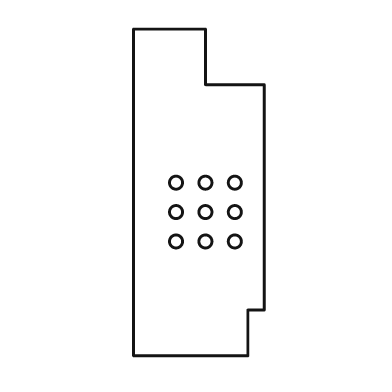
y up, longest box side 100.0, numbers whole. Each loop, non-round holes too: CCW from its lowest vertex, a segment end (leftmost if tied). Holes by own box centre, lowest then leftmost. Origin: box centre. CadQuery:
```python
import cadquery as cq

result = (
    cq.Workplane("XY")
    .moveTo(-20.0, -50.0)
    .lineTo(15.0, -50.0)
    .lineTo(15.0, -36.0)
    .lineTo(20.0, -36.0)
    .lineTo(20.0, 33.0)
    .lineTo(2.0, 33.0)
    .lineTo(2.0, 50.0)
    .lineTo(-20.0, 50.0)
    .close()
    .moveTo(-7.0, -15.0)
    .circle(2.0)
    .moveTo(2.0, -15.0)
    .circle(2.0)
    .moveTo(11.0, -15.0)
    .circle(2.0)
    .moveTo(-7.0, -6.0)
    .circle(2.0)
    .moveTo(2.0, -6.0)
    .circle(2.0)
    .moveTo(11.0, -6.0)
    .circle(2.0)
    .moveTo(-7.0, 3.0)
    .circle(2.0)
    .moveTo(2.0, 3.0)
    .circle(2.0)
    .moveTo(11.0, 3.0)
    .circle(2.0)
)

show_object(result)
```